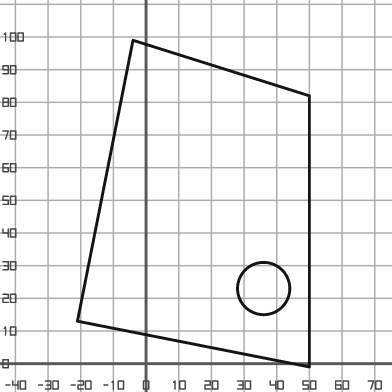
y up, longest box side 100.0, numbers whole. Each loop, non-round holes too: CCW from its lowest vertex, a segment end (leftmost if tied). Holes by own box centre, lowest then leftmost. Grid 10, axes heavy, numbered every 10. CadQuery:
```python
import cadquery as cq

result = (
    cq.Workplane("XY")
    .moveTo(50.0, -1.0)
    .lineTo(50.0, 82.0)
    .lineTo(-4.0, 99.0)
    .lineTo(-21.0, 13.0)
    .close()
    .moveTo(36.0, 23.0)
    .circle(8.0)
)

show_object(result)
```